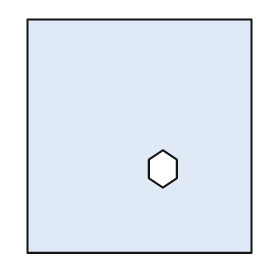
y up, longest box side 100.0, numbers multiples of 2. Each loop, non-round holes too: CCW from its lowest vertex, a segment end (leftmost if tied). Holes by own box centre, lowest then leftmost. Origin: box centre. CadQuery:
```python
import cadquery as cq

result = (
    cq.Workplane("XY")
    .moveTo(-48.0, -50.0)
    .lineTo(48.0, -50.0)
    .lineTo(48.0, 50.0)
    .lineTo(-48.0, 50.0)
    .close()
    .moveTo(10.0, -22.0)
    .lineTo(16.0, -18.0)
    .lineTo(16.0, -10.0)
    .lineTo(10.0, -6.0)
    .lineTo(4.0, -10.0)
    .lineTo(4.0, -18.0)
    .close()
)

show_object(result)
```